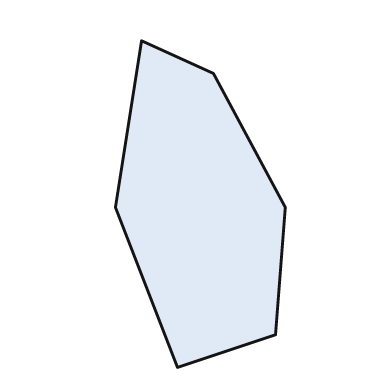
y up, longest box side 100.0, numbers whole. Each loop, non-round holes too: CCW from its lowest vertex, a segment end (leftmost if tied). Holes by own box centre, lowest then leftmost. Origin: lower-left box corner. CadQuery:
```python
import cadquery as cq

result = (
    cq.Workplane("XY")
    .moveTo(19.0, 0.0)
    .lineTo(49.0, 10.0)
    .lineTo(52.0, 49.0)
    .lineTo(30.0, 90.0)
    .lineTo(8.0, 100.0)
    .lineTo(0.0, 49.0)
    .close()
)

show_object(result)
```